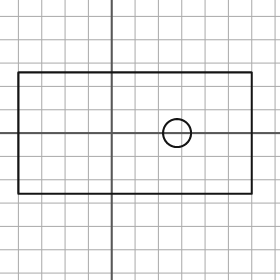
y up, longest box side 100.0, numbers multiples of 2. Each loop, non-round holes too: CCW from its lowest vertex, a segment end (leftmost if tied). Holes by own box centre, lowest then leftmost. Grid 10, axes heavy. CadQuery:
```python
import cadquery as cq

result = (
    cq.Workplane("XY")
    .moveTo(-40.0, -26.0)
    .lineTo(60.0, -26.0)
    .lineTo(60.0, 26.0)
    .lineTo(-40.0, 26.0)
    .close()
    .moveTo(28.0, 0.0)
    .circle(6.0)
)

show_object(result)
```